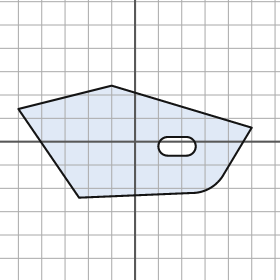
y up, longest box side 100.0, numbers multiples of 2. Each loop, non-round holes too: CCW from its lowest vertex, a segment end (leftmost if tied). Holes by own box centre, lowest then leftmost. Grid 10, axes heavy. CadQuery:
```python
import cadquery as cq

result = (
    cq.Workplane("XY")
    .moveTo(-24.0, -24.0)
    .lineTo(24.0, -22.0)
    .threePointArc((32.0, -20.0), (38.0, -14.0))
    .lineTo(50.0, 6.0)
    .lineTo(-10.0, 24.0)
    .lineTo(-50.0, 14.0)
    .close()
    .moveTo(14.0, -6.0)
    .lineTo(22.0, -6.0)
    .threePointArc((26.0, -2.0), (22.0, 2.0))
    .lineTo(14.0, 2.0)
    .threePointArc((10.0, -2.0), (14.0, -6.0))
    .close()
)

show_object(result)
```